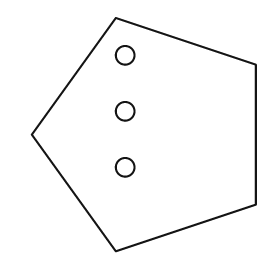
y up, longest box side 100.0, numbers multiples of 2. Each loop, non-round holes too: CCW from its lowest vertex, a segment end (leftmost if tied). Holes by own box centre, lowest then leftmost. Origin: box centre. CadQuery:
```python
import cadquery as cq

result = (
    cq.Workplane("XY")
    .moveTo(-12.0, -50.0)
    .lineTo(48.0, -30.0)
    .lineTo(48.0, 30.0)
    .lineTo(-12.0, 50.0)
    .lineTo(-48.0, 0.0)
    .close()
    .moveTo(-8.0, -14.0)
    .circle(4.0)
    .moveTo(-8.0, 10.0)
    .circle(4.0)
    .moveTo(-8.0, 34.0)
    .circle(4.0)
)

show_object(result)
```